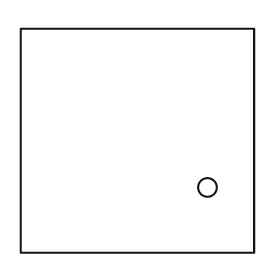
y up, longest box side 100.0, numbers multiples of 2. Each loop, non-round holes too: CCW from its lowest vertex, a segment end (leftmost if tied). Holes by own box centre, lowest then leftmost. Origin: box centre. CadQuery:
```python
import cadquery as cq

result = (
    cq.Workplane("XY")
    .moveTo(-50.0, -48.0)
    .lineTo(50.0, -48.0)
    .lineTo(50.0, 48.0)
    .lineTo(-50.0, 48.0)
    .close()
    .moveTo(30.0, -20.0)
    .circle(4.0)
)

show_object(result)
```